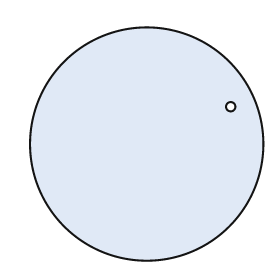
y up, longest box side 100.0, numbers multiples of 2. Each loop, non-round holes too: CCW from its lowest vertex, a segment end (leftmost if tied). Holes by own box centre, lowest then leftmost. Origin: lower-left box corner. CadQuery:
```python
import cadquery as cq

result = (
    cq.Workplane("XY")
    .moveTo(50.0, 50.0)
    .circle(50.0)
    .moveTo(86.0, 66.0)
    .circle(2.0)
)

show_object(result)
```